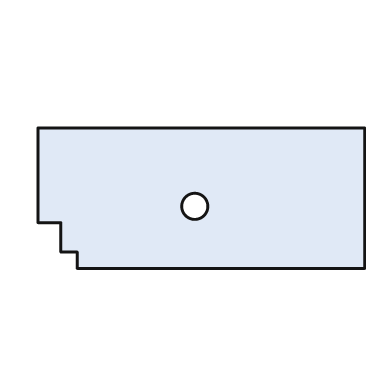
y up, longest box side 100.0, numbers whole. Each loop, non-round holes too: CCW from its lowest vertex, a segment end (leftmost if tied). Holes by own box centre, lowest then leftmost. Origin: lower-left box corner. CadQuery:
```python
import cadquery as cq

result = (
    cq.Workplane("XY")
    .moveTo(12.0, 0.0)
    .lineTo(100.0, 0.0)
    .lineTo(100.0, 43.0)
    .lineTo(0.0, 43.0)
    .lineTo(0.0, 14.0)
    .lineTo(7.0, 14.0)
    .lineTo(7.0, 5.0)
    .lineTo(12.0, 5.0)
    .close()
    .moveTo(48.0, 19.0)
    .circle(4.0)
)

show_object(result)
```